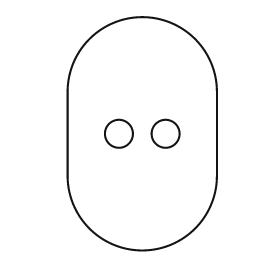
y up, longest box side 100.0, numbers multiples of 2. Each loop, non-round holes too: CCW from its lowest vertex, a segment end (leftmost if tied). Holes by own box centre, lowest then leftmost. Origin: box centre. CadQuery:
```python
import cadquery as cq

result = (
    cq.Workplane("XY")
    .moveTo(-32.0, -18.0)
    .threePointArc((0.0, -50.0), (32.0, -18.0))
    .lineTo(32.0, 18.0)
    .threePointArc((0.0, 50.0), (-32.0, 18.0))
    .close()
    .moveTo(-10.0, 0.0)
    .circle(6.0)
    .moveTo(10.0, 0.0)
    .circle(6.0)
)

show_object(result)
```